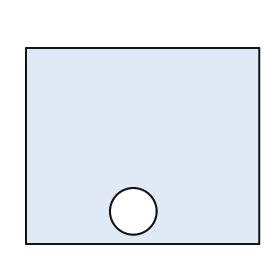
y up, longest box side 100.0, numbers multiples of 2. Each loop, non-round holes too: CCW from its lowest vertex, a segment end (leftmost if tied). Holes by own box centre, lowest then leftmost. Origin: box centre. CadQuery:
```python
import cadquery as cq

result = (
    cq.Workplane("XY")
    .moveTo(-50.0, -42.0)
    .lineTo(50.0, -42.0)
    .lineTo(50.0, 42.0)
    .lineTo(-50.0, 42.0)
    .close()
    .moveTo(-4.0, -28.0)
    .circle(10.0)
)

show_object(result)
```